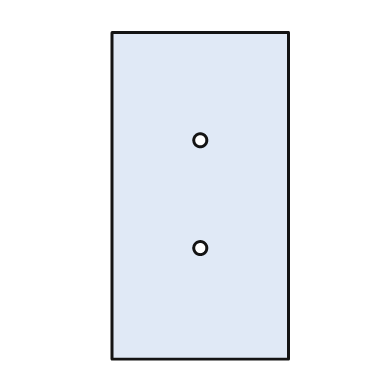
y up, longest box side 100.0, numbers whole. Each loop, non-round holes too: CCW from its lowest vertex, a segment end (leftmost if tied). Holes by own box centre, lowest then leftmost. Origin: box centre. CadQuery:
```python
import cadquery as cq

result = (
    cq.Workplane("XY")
    .moveTo(-27.0, -50.0)
    .lineTo(27.0, -50.0)
    .lineTo(27.0, 50.0)
    .lineTo(-27.0, 50.0)
    .close()
    .moveTo(0.0, -16.0)
    .circle(2.0)
    .moveTo(0.0, 17.0)
    .circle(2.0)
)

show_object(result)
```